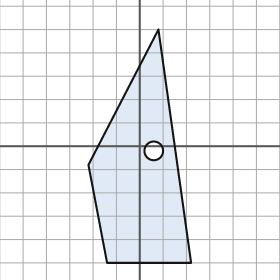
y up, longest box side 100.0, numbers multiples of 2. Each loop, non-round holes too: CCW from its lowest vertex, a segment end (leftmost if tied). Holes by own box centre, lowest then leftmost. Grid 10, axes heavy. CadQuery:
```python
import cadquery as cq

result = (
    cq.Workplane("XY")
    .moveTo(-14.0, -50.0)
    .lineTo(22.0, -50.0)
    .lineTo(8.0, 50.0)
    .lineTo(-22.0, -8.0)
    .close()
    .moveTo(6.0, -2.0)
    .circle(4.0)
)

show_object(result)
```